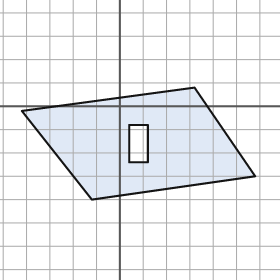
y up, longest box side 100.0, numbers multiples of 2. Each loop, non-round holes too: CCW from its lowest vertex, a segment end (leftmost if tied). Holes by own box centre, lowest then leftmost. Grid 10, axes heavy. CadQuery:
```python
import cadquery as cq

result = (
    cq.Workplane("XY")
    .moveTo(-12.0, -40.0)
    .lineTo(58.0, -30.0)
    .lineTo(32.0, 8.0)
    .lineTo(-42.0, -2.0)
    .close()
    .moveTo(4.0, -24.0)
    .lineTo(12.0, -24.0)
    .lineTo(12.0, -8.0)
    .lineTo(4.0, -8.0)
    .close()
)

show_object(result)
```